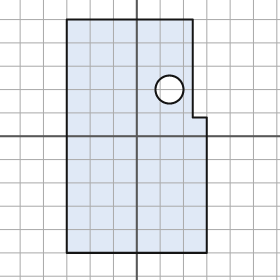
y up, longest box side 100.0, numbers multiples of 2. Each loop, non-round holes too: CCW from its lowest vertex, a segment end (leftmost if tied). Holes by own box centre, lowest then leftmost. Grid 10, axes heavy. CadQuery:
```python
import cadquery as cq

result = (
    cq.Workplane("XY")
    .moveTo(-30.0, -50.0)
    .lineTo(30.0, -50.0)
    .lineTo(30.0, 8.0)
    .lineTo(24.0, 8.0)
    .lineTo(24.0, 50.0)
    .lineTo(-30.0, 50.0)
    .close()
    .moveTo(14.0, 20.0)
    .circle(6.0)
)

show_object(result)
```